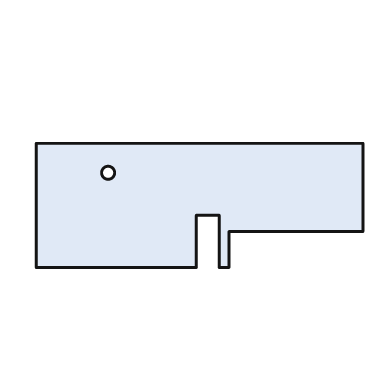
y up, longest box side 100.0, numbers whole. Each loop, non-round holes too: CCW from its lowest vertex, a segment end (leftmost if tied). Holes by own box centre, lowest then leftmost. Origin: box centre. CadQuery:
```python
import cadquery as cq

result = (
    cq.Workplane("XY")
    .moveTo(-50.0, -19.0)
    .lineTo(-1.0, -19.0)
    .lineTo(-1.0, -3.0)
    .lineTo(6.0, -3.0)
    .lineTo(6.0, -19.0)
    .lineTo(9.0, -19.0)
    .lineTo(9.0, -8.0)
    .lineTo(50.0, -8.0)
    .lineTo(50.0, 19.0)
    .lineTo(-50.0, 19.0)
    .close()
    .moveTo(-28.0, 10.0)
    .circle(2.0)
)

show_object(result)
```